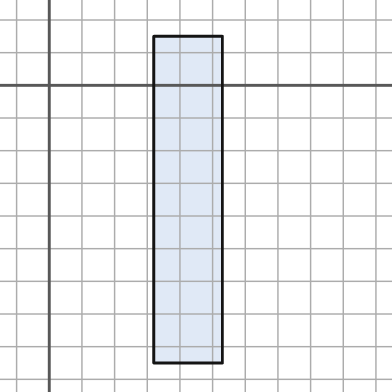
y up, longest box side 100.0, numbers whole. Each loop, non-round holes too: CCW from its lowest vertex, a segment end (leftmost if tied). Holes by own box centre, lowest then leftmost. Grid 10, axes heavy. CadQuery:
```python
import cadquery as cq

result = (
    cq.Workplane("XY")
    .moveTo(32.0, -85.0)
    .lineTo(53.0, -85.0)
    .lineTo(53.0, 15.0)
    .lineTo(32.0, 15.0)
    .close()
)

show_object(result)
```